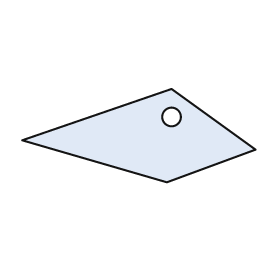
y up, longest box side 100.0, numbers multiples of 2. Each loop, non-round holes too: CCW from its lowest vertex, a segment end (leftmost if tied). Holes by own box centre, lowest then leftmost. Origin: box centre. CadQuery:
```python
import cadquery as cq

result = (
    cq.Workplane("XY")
    .moveTo(12.0, -20.0)
    .lineTo(50.0, -6.0)
    .lineTo(14.0, 20.0)
    .lineTo(-50.0, -2.0)
    .close()
    .moveTo(14.0, 8.0)
    .circle(4.0)
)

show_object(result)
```